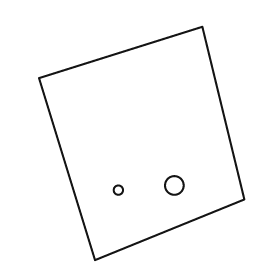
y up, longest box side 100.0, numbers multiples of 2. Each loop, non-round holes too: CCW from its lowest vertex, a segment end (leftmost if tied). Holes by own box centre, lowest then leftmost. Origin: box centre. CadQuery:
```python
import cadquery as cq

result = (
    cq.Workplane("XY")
    .moveTo(-20.0, -50.0)
    .lineTo(44.0, -24.0)
    .lineTo(26.0, 50.0)
    .lineTo(-44.0, 28.0)
    .close()
    .moveTo(-10.0, -20.0)
    .circle(2.0)
    .moveTo(14.0, -18.0)
    .circle(4.0)
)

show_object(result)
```